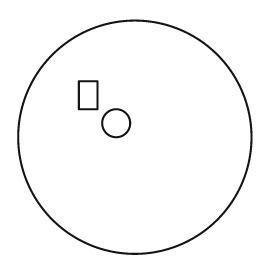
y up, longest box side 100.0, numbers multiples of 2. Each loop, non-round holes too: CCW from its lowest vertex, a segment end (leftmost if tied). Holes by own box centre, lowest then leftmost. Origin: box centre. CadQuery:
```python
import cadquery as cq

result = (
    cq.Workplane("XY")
    .moveTo(0.0, 0.0)
    .circle(50.0)
    .moveTo(-8.0, 6.0)
    .circle(6.0)
    .moveTo(-24.0, 12.0)
    .lineTo(-16.0, 12.0)
    .lineTo(-16.0, 24.0)
    .lineTo(-24.0, 24.0)
    .close()
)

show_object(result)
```